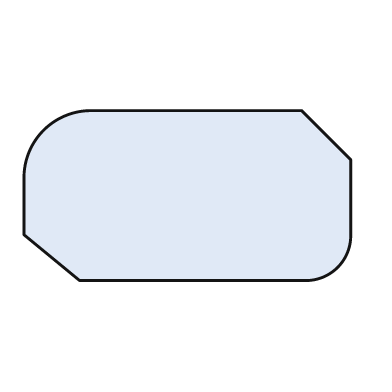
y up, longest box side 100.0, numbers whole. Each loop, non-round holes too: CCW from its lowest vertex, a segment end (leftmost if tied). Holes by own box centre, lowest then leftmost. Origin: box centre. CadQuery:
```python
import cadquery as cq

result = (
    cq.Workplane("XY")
    .moveTo(-33.0, -26.0)
    .lineTo(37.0, -26.0)
    .threePointArc((46.0, -22.0), (50.0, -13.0))
    .lineTo(50.0, 11.0)
    .lineTo(35.0, 26.0)
    .lineTo(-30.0, 26.0)
    .threePointArc((-44.0, 20.0), (-50.0, 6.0))
    .lineTo(-50.0, -12.0)
    .close()
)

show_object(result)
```